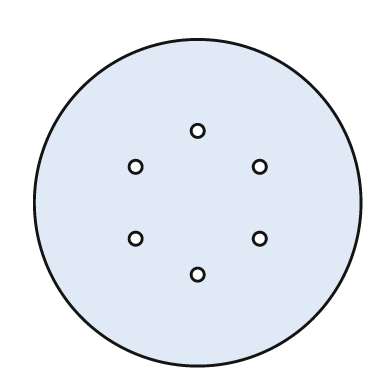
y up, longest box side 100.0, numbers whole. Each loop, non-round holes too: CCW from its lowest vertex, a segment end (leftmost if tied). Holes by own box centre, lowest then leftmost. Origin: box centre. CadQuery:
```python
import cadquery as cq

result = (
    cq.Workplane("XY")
    .moveTo(0.0, 0.0)
    .circle(50.0)
    .moveTo(0.0, -22.0)
    .circle(2.0)
    .moveTo(-19.0, -11.0)
    .circle(2.0)
    .moveTo(19.0, -11.0)
    .circle(2.0)
    .moveTo(-19.0, 11.0)
    .circle(2.0)
    .moveTo(19.0, 11.0)
    .circle(2.0)
    .moveTo(0.0, 22.0)
    .circle(2.0)
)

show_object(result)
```